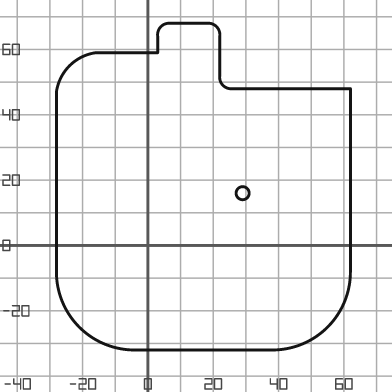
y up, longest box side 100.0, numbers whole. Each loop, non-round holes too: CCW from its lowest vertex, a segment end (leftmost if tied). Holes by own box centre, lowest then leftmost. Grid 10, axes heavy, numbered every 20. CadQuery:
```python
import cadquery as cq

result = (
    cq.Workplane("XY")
    .moveTo(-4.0, -32.0)
    .lineTo(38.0, -32.0)
    .threePointArc((55.0, -25.0), (62.0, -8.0))
    .lineTo(62.0, 48.0)
    .lineTo(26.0, 48.0)
    .threePointArc((23.0, 49.0), (22.0, 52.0))
    .lineTo(22.0, 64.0)
    .threePointArc((21.0, 67.0), (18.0, 68.0))
    .lineTo(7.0, 68.0)
    .threePointArc((4.0, 67.0), (3.0, 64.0))
    .lineTo(3.0, 59.0)
    .lineTo(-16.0, 59.0)
    .threePointArc((-24.0, 55.0), (-28.0, 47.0))
    .lineTo(-28.0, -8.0)
    .threePointArc((-21.0, -25.0), (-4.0, -32.0))
    .close()
    .moveTo(29.0, 16.0)
    .circle(2.0)
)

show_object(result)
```